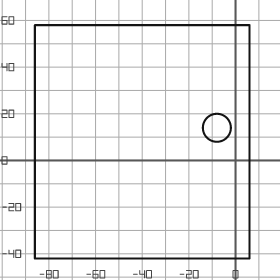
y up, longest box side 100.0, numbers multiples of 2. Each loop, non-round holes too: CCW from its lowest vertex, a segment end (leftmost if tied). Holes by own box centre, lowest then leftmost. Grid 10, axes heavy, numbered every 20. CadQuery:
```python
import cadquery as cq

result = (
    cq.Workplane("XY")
    .moveTo(-86.0, -42.0)
    .lineTo(6.0, -42.0)
    .lineTo(6.0, 58.0)
    .lineTo(-86.0, 58.0)
    .close()
    .moveTo(-8.0, 14.0)
    .circle(6.0)
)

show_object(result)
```